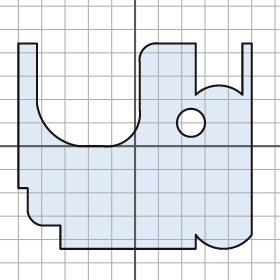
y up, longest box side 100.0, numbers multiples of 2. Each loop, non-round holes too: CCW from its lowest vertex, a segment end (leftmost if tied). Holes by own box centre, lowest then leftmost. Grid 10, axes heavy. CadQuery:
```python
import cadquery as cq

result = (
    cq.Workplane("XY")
    .moveTo(-32.0, -44.0)
    .lineTo(26.0, -44.0)
    .lineTo(26.0, -38.0)
    .threePointArc((38.0, -44.0), (50.0, -38.0))
    .lineTo(50.0, 44.0)
    .lineTo(46.0, 44.0)
    .lineTo(46.0, 22.0)
    .threePointArc((36.0, 26.0), (26.0, 22.0))
    .lineTo(26.0, 44.0)
    .lineTo(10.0, 44.0)
    .threePointArc((4.0, 42.0), (2.0, 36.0))
    .lineTo(2.0, 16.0)
    .threePointArc((-2.0, 4.0), (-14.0, 0.0))
    .lineTo(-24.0, 0.0)
    .threePointArc((-36.0, 6.0), (-42.0, 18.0))
    .lineTo(-42.0, 44.0)
    .lineTo(-50.0, 44.0)
    .lineTo(-50.0, -18.0)
    .lineTo(-46.0, -18.0)
    .lineTo(-46.0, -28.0)
    .threePointArc((-44.0, -32.0), (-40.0, -34.0))
    .lineTo(-32.0, -34.0)
    .close()
    .moveTo(24.0, 10.0)
    .circle(6.0)
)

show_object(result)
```